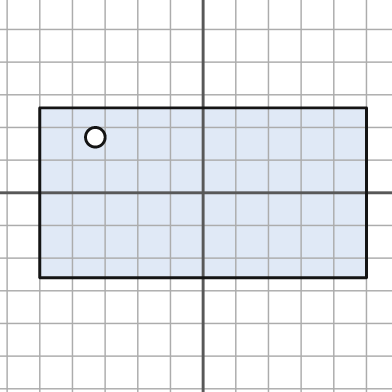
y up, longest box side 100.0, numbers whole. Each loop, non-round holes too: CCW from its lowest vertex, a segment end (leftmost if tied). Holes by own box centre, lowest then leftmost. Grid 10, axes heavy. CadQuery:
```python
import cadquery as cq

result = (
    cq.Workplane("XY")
    .moveTo(-50.0, -26.0)
    .lineTo(50.0, -26.0)
    .lineTo(50.0, 26.0)
    .lineTo(-50.0, 26.0)
    .close()
    .moveTo(-33.0, 17.0)
    .circle(3.0)
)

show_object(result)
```